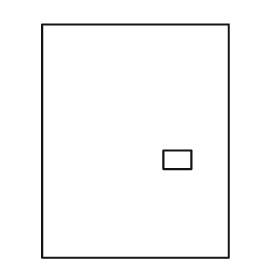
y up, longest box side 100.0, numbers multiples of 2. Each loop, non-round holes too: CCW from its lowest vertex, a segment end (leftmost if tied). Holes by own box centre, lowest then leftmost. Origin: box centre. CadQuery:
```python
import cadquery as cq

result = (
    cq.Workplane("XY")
    .moveTo(-40.0, -50.0)
    .lineTo(40.0, -50.0)
    .lineTo(40.0, 50.0)
    .lineTo(-40.0, 50.0)
    .close()
    .moveTo(12.0, -12.0)
    .lineTo(24.0, -12.0)
    .lineTo(24.0, -4.0)
    .lineTo(12.0, -4.0)
    .close()
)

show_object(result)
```